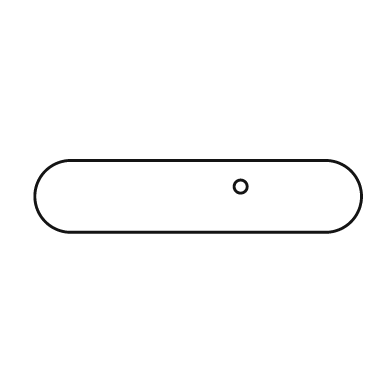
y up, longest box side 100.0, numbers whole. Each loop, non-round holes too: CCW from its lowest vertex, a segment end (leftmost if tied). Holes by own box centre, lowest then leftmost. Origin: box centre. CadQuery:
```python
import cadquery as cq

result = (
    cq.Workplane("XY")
    .moveTo(-39.0, -11.0)
    .lineTo(39.0, -11.0)
    .threePointArc((50.0, 0.0), (39.0, 11.0))
    .lineTo(-39.0, 11.0)
    .threePointArc((-50.0, 0.0), (-39.0, -11.0))
    .close()
    .moveTo(13.0, 3.0)
    .circle(2.0)
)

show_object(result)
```